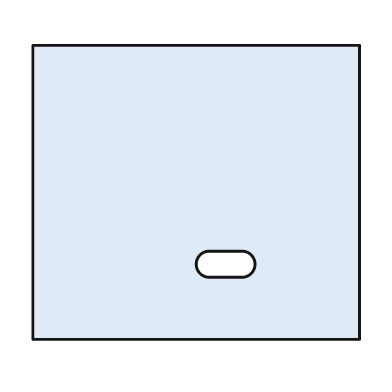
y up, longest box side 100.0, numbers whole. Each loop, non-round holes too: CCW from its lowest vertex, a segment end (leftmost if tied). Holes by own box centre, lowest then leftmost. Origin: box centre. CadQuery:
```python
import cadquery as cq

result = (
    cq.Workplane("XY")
    .moveTo(-50.0, -45.0)
    .lineTo(50.0, -45.0)
    .lineTo(50.0, 45.0)
    .lineTo(-50.0, 45.0)
    .close()
    .moveTo(4.0, -26.0)
    .lineTo(14.0, -26.0)
    .threePointArc((18.0, -22.0), (14.0, -18.0))
    .lineTo(4.0, -18.0)
    .threePointArc((0.0, -22.0), (4.0, -26.0))
    .close()
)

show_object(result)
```